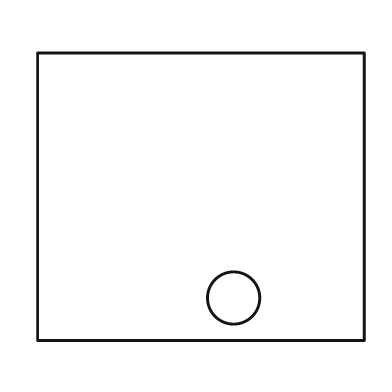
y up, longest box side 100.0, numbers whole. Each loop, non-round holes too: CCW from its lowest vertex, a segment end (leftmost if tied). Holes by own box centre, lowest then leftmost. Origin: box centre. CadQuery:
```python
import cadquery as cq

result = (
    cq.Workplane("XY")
    .moveTo(-50.0, -44.0)
    .lineTo(50.0, -44.0)
    .lineTo(50.0, 44.0)
    .lineTo(-50.0, 44.0)
    .close()
    .moveTo(10.0, -31.0)
    .circle(8.0)
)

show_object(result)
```